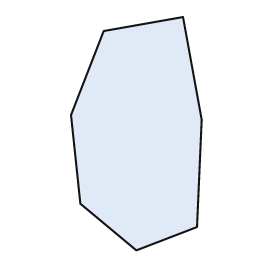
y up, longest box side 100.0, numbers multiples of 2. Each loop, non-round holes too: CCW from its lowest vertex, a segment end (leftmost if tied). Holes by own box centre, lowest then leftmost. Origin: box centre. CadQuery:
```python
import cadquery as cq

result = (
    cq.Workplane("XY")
    .moveTo(0.0, -50.0)
    .lineTo(26.0, -40.0)
    .lineTo(28.0, 6.0)
    .lineTo(20.0, 50.0)
    .lineTo(-14.0, 44.0)
    .lineTo(-28.0, 8.0)
    .lineTo(-24.0, -30.0)
    .close()
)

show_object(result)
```